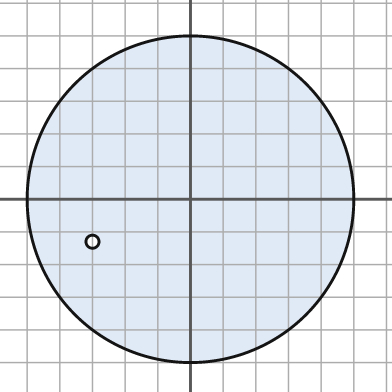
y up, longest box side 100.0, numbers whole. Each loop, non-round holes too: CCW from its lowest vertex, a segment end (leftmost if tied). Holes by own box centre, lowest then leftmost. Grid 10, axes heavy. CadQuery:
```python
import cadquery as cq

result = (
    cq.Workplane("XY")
    .moveTo(0.0, 0.0)
    .circle(50.0)
    .moveTo(-30.0, -13.0)
    .circle(2.0)
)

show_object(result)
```